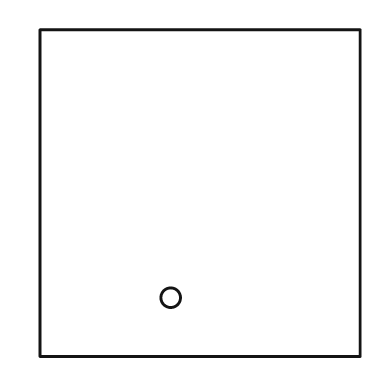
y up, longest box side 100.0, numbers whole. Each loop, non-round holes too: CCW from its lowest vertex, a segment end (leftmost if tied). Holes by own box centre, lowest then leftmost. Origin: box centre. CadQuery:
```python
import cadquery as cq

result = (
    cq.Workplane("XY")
    .moveTo(-49.0, -50.0)
    .lineTo(49.0, -50.0)
    .lineTo(49.0, 50.0)
    .lineTo(-49.0, 50.0)
    .close()
    .moveTo(-9.0, -32.0)
    .circle(3.0)
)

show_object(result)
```